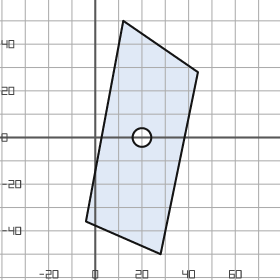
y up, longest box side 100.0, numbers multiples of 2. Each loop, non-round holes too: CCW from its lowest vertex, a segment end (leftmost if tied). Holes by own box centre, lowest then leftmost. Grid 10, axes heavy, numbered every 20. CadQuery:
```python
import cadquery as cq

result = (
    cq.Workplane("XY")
    .moveTo(28.0, -50.0)
    .lineTo(44.0, 28.0)
    .lineTo(12.0, 50.0)
    .lineTo(-4.0, -36.0)
    .close()
    .moveTo(20.0, 0.0)
    .circle(4.0)
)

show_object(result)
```